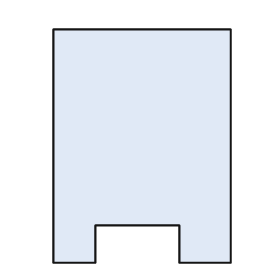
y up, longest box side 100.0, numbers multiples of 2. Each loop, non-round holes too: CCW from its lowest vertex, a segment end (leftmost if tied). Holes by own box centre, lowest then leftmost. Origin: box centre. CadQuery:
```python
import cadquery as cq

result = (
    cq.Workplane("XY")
    .moveTo(-38.0, -50.0)
    .lineTo(-20.0, -50.0)
    .lineTo(-20.0, -34.0)
    .lineTo(16.0, -34.0)
    .lineTo(16.0, -50.0)
    .lineTo(38.0, -50.0)
    .lineTo(38.0, 50.0)
    .lineTo(-38.0, 50.0)
    .close()
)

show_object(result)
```